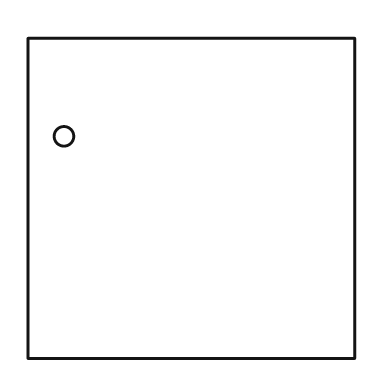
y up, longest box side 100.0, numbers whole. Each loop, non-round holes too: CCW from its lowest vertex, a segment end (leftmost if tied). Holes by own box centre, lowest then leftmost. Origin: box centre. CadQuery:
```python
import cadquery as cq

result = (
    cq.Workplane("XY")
    .moveTo(-50.0, -49.0)
    .lineTo(50.0, -49.0)
    .lineTo(50.0, 49.0)
    .lineTo(-50.0, 49.0)
    .close()
    .moveTo(-39.0, 19.0)
    .circle(3.0)
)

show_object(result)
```